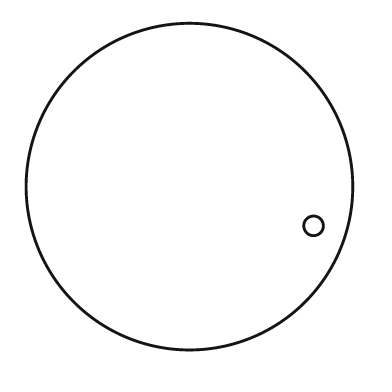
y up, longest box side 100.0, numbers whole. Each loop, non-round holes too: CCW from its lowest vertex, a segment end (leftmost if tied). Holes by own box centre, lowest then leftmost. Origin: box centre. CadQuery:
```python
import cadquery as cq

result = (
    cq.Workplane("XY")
    .moveTo(0.0, 0.0)
    .circle(50.0)
    .moveTo(38.0, -12.0)
    .circle(3.0)
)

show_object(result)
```